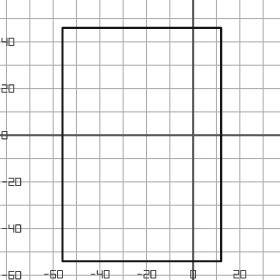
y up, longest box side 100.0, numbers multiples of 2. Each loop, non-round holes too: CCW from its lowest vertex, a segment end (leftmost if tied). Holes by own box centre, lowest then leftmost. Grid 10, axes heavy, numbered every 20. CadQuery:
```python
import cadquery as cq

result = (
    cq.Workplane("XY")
    .moveTo(-56.0, -54.0)
    .lineTo(12.0, -54.0)
    .lineTo(12.0, 46.0)
    .lineTo(-56.0, 46.0)
    .close()
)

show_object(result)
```